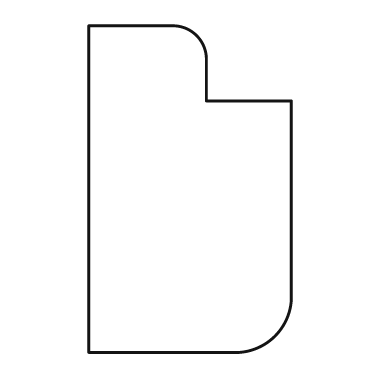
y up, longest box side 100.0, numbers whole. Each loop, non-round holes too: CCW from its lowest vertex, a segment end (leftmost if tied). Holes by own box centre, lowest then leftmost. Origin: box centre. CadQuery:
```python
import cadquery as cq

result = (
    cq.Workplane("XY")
    .moveTo(-31.0, -50.0)
    .lineTo(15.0, -50.0)
    .threePointArc((26.0, -45.0), (31.0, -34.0))
    .lineTo(31.0, 27.0)
    .lineTo(5.0, 27.0)
    .lineTo(5.0, 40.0)
    .threePointArc((2.0, 47.0), (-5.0, 50.0))
    .lineTo(-31.0, 50.0)
    .close()
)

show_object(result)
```